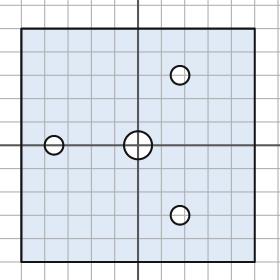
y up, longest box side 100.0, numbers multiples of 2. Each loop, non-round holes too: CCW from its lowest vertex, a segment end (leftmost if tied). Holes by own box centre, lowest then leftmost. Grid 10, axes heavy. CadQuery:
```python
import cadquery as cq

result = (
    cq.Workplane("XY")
    .moveTo(-50.0, -50.0)
    .lineTo(50.0, -50.0)
    .lineTo(50.0, 50.0)
    .lineTo(-50.0, 50.0)
    .close()
    .moveTo(18.0, -30.0)
    .circle(4.0)
    .moveTo(-36.0, 0.0)
    .circle(4.0)
    .moveTo(0.0, 0.0)
    .circle(6.0)
    .moveTo(18.0, 30.0)
    .circle(4.0)
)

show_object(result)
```